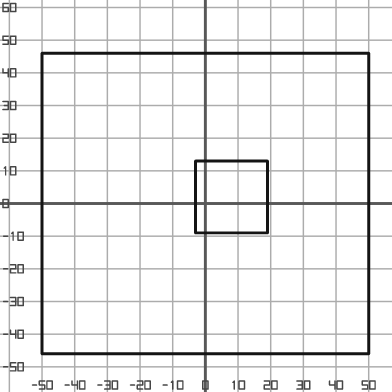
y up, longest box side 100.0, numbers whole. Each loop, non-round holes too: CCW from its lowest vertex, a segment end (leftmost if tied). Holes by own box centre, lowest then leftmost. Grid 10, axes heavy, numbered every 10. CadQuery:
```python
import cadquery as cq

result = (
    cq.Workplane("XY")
    .moveTo(-50.0, -46.0)
    .lineTo(50.0, -46.0)
    .lineTo(50.0, 46.0)
    .lineTo(-50.0, 46.0)
    .close()
    .moveTo(-3.0, -9.0)
    .lineTo(19.0, -9.0)
    .lineTo(19.0, 13.0)
    .lineTo(-3.0, 13.0)
    .close()
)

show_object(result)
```